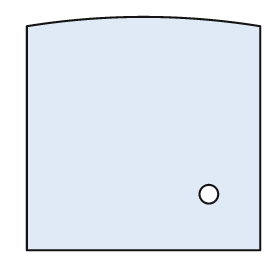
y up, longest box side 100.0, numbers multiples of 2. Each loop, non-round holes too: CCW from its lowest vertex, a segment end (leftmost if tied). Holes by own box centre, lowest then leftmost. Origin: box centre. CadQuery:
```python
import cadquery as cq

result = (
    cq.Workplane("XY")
    .moveTo(-50.0, -50.0)
    .lineTo(50.0, -50.0)
    .lineTo(50.0, 46.0)
    .threePointArc((0.0, 50.0), (-50.0, 46.0))
    .close()
    .moveTo(28.0, -26.0)
    .circle(4.0)
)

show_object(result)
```